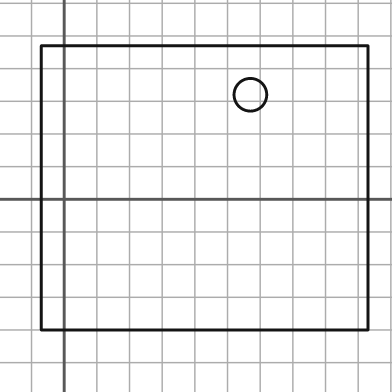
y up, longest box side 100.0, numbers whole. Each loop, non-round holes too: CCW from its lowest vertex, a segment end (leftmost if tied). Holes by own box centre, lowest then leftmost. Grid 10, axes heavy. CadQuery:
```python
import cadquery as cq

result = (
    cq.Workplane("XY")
    .moveTo(-7.0, -40.0)
    .lineTo(93.0, -40.0)
    .lineTo(93.0, 47.0)
    .lineTo(-7.0, 47.0)
    .close()
    .moveTo(57.0, 32.0)
    .circle(5.0)
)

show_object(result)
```